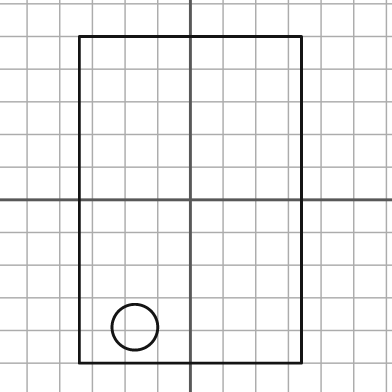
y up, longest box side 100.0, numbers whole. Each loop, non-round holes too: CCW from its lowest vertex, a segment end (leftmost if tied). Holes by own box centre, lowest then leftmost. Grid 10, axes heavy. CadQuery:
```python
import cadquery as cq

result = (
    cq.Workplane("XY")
    .moveTo(-34.0, -50.0)
    .lineTo(34.0, -50.0)
    .lineTo(34.0, 50.0)
    .lineTo(-34.0, 50.0)
    .close()
    .moveTo(-17.0, -39.0)
    .circle(7.0)
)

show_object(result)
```